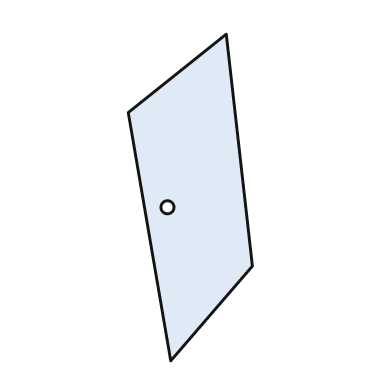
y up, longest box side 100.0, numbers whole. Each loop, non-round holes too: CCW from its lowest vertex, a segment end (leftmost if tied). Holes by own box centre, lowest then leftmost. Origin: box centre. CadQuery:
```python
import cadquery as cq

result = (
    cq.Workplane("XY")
    .moveTo(-6.0, -50.0)
    .lineTo(19.0, -21.0)
    .lineTo(11.0, 50.0)
    .lineTo(-19.0, 26.0)
    .close()
    .moveTo(-7.0, -3.0)
    .circle(2.0)
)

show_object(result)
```